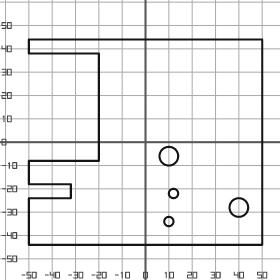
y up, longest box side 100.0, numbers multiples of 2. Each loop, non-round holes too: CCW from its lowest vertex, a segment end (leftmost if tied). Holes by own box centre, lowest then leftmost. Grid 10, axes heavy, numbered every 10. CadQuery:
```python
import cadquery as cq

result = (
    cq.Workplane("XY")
    .moveTo(-50.0, -44.0)
    .lineTo(50.0, -44.0)
    .lineTo(50.0, 44.0)
    .lineTo(-50.0, 44.0)
    .lineTo(-50.0, 38.0)
    .lineTo(-20.0, 38.0)
    .lineTo(-20.0, -8.0)
    .lineTo(-50.0, -8.0)
    .lineTo(-50.0, -18.0)
    .lineTo(-32.0, -18.0)
    .lineTo(-32.0, -24.0)
    .lineTo(-50.0, -24.0)
    .close()
    .moveTo(10.0, -34.0)
    .circle(2.0)
    .moveTo(40.0, -28.0)
    .circle(4.0)
    .moveTo(12.0, -22.0)
    .circle(2.0)
    .moveTo(10.0, -6.0)
    .circle(4.0)
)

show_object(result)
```